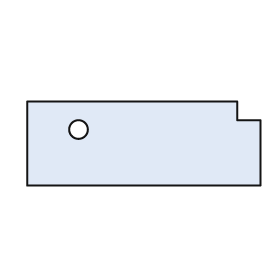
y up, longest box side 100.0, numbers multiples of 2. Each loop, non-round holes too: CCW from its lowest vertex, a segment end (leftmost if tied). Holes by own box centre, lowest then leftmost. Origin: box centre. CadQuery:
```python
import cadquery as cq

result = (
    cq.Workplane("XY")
    .moveTo(-50.0, -18.0)
    .lineTo(50.0, -18.0)
    .lineTo(50.0, 10.0)
    .lineTo(40.0, 10.0)
    .lineTo(40.0, 18.0)
    .lineTo(-50.0, 18.0)
    .close()
    .moveTo(-28.0, 6.0)
    .circle(4.0)
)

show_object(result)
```